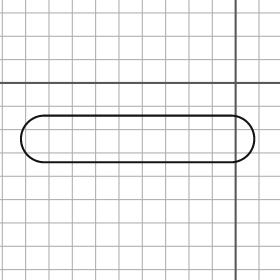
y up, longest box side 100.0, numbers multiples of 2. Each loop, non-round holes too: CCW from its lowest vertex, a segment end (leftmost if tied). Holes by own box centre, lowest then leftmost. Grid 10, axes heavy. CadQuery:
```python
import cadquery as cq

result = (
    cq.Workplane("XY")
    .moveTo(-82.0, -34.0)
    .lineTo(-2.0, -34.0)
    .threePointArc((8.0, -24.0), (-2.0, -14.0))
    .lineTo(-82.0, -14.0)
    .threePointArc((-92.0, -24.0), (-82.0, -34.0))
    .close()
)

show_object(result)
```